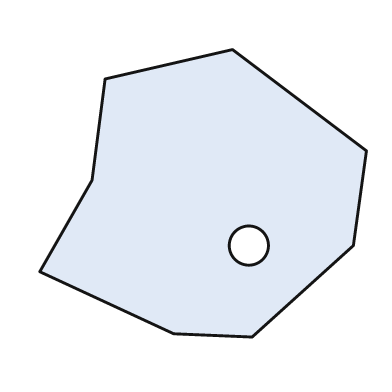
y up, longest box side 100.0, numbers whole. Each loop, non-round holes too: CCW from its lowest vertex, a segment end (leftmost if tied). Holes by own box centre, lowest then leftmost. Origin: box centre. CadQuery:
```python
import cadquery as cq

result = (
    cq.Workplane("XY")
    .moveTo(15.0, -44.0)
    .lineTo(46.0, -16.0)
    .lineTo(50.0, 13.0)
    .lineTo(9.0, 44.0)
    .lineTo(-30.0, 35.0)
    .lineTo(-34.0, 4.0)
    .lineTo(-50.0, -24.0)
    .lineTo(-9.0, -43.0)
    .close()
    .moveTo(14.0, -16.0)
    .circle(6.0)
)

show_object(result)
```